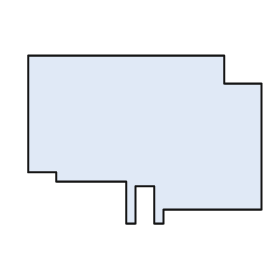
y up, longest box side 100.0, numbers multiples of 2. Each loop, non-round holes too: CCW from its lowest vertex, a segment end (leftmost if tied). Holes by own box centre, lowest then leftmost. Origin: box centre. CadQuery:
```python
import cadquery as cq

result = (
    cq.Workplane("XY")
    .moveTo(-8.0, -36.0)
    .lineTo(-4.0, -36.0)
    .lineTo(-4.0, -20.0)
    .lineTo(4.0, -20.0)
    .lineTo(4.0, -36.0)
    .lineTo(8.0, -36.0)
    .lineTo(8.0, -30.0)
    .lineTo(50.0, -30.0)
    .lineTo(50.0, 24.0)
    .lineTo(34.0, 24.0)
    .lineTo(34.0, 36.0)
    .lineTo(-50.0, 36.0)
    .lineTo(-50.0, -14.0)
    .lineTo(-38.0, -14.0)
    .lineTo(-38.0, -18.0)
    .lineTo(-8.0, -18.0)
    .close()
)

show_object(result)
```